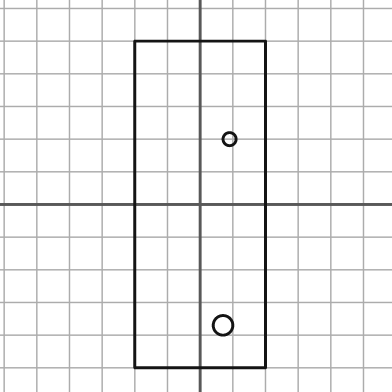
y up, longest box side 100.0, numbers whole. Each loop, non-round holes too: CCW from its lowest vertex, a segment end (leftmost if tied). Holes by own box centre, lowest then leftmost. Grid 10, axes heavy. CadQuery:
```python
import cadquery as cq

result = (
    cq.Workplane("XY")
    .moveTo(-20.0, -50.0)
    .lineTo(20.0, -50.0)
    .lineTo(20.0, 50.0)
    .lineTo(-20.0, 50.0)
    .close()
    .moveTo(7.0, -37.0)
    .circle(3.0)
    .moveTo(9.0, 20.0)
    .circle(2.0)
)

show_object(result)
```